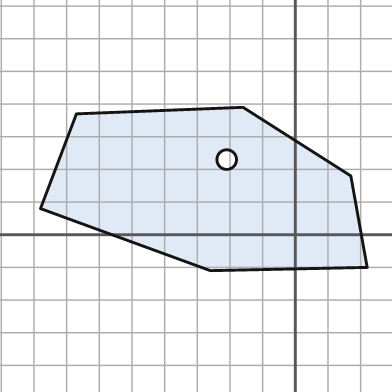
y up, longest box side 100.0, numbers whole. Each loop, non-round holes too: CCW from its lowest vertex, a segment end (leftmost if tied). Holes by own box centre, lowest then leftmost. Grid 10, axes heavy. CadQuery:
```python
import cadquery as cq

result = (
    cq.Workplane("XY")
    .moveTo(-26.0, -11.0)
    .lineTo(22.0, -10.0)
    .lineTo(17.0, 18.0)
    .lineTo(-16.0, 39.0)
    .lineTo(-67.0, 37.0)
    .lineTo(-78.0, 8.0)
    .close()
    .moveTo(-21.0, 23.0)
    .circle(3.0)
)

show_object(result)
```